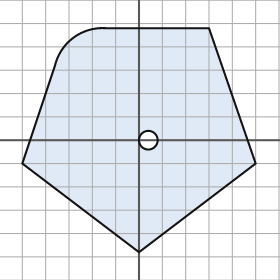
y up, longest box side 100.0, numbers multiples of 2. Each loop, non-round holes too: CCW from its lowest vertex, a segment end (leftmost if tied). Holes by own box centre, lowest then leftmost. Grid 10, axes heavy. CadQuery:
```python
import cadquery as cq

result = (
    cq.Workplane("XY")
    .moveTo(0.0, -48.0)
    .lineTo(50.0, -10.0)
    .lineTo(30.0, 48.0)
    .lineTo(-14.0, 48.0)
    .threePointArc((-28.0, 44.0), (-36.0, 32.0))
    .lineTo(-50.0, -10.0)
    .close()
    .moveTo(4.0, 0.0)
    .circle(4.0)
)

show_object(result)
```